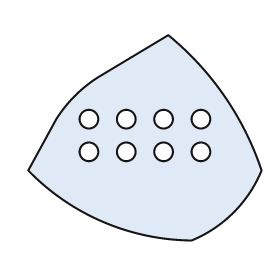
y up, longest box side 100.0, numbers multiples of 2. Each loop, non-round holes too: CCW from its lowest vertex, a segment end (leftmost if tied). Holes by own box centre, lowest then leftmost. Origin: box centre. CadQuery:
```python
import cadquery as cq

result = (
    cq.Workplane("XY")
    .moveTo(20.0, -44.0)
    .threePointArc((38.0, -32.0), (50.0, -14.0))
    .threePointArc((34.0, 18.0), (10.0, 44.0))
    .lineTo(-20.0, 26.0)
    .threePointArc((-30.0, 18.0), (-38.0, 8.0))
    .lineTo(-50.0, -14.0)
    .threePointArc((-18.0, -36.0), (20.0, -44.0))
    .close()
    .moveTo(-24.0, -6.0)
    .circle(4.0)
    .moveTo(-8.0, -6.0)
    .circle(4.0)
    .moveTo(8.0, -6.0)
    .circle(4.0)
    .moveTo(24.0, -6.0)
    .circle(4.0)
    .moveTo(-24.0, 8.0)
    .circle(4.0)
    .moveTo(-8.0, 8.0)
    .circle(4.0)
    .moveTo(8.0, 8.0)
    .circle(4.0)
    .moveTo(24.0, 8.0)
    .circle(4.0)
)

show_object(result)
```